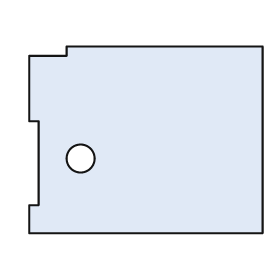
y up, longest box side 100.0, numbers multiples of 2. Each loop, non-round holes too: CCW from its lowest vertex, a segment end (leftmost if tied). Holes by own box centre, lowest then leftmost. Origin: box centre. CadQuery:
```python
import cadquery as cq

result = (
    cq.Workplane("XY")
    .moveTo(-50.0, -40.0)
    .lineTo(50.0, -40.0)
    .lineTo(50.0, 40.0)
    .lineTo(-34.0, 40.0)
    .lineTo(-34.0, 36.0)
    .lineTo(-50.0, 36.0)
    .lineTo(-50.0, 8.0)
    .lineTo(-46.0, 8.0)
    .lineTo(-46.0, -28.0)
    .lineTo(-50.0, -28.0)
    .close()
    .moveTo(-28.0, -8.0)
    .circle(6.0)
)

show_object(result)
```